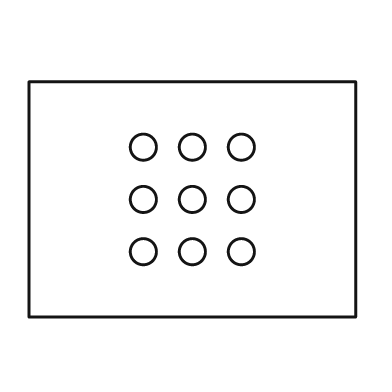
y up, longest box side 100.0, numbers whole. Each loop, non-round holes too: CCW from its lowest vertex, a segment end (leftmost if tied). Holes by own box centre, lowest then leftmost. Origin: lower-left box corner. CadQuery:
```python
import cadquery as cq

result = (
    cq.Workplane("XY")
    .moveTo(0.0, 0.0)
    .lineTo(100.0, 0.0)
    .lineTo(100.0, 72.0)
    .lineTo(0.0, 72.0)
    .close()
    .moveTo(35.0, 20.0)
    .circle(4.0)
    .moveTo(50.0, 20.0)
    .circle(4.0)
    .moveTo(65.0, 20.0)
    .circle(4.0)
    .moveTo(35.0, 36.0)
    .circle(4.0)
    .moveTo(50.0, 36.0)
    .circle(4.0)
    .moveTo(65.0, 36.0)
    .circle(4.0)
    .moveTo(35.0, 52.0)
    .circle(4.0)
    .moveTo(50.0, 52.0)
    .circle(4.0)
    .moveTo(65.0, 52.0)
    .circle(4.0)
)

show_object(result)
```